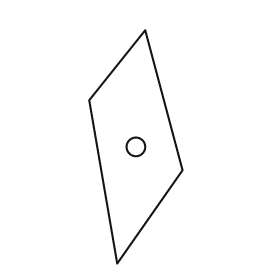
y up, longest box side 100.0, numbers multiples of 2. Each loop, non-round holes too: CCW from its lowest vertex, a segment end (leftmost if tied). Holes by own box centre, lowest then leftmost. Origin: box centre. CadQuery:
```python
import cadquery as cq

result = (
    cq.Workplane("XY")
    .moveTo(-8.0, -50.0)
    .lineTo(20.0, -10.0)
    .lineTo(4.0, 50.0)
    .lineTo(-20.0, 20.0)
    .close()
    .moveTo(0.0, 0.0)
    .circle(4.0)
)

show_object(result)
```